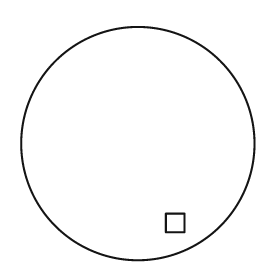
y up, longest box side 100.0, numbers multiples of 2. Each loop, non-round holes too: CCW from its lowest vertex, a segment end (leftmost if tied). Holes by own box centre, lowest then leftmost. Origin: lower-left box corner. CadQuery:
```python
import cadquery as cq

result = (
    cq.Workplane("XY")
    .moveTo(50.0, 50.0)
    .circle(50.0)
    .moveTo(62.0, 12.0)
    .lineTo(70.0, 12.0)
    .lineTo(70.0, 20.0)
    .lineTo(62.0, 20.0)
    .close()
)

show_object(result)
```